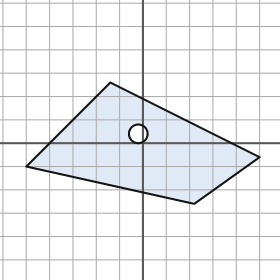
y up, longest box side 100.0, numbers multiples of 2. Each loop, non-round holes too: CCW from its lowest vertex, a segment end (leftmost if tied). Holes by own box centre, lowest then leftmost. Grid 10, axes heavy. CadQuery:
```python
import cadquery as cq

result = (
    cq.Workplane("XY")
    .moveTo(22.0, -26.0)
    .lineTo(50.0, -6.0)
    .lineTo(-14.0, 26.0)
    .lineTo(-50.0, -10.0)
    .close()
    .moveTo(-2.0, 4.0)
    .circle(4.0)
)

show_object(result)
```